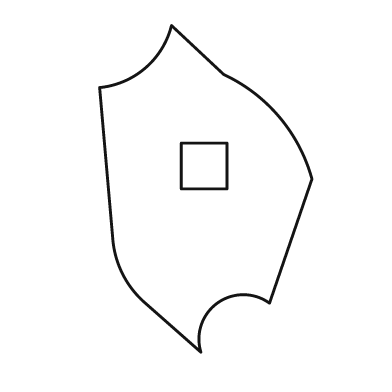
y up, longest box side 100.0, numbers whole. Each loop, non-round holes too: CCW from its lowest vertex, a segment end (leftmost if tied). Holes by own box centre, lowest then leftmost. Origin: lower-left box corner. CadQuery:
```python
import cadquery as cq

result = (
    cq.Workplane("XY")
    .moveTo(31.0, 0.0)
    .threePointArc((36.0, 15.0), (52.0, 15.0))
    .lineTo(65.0, 53.0)
    .threePointArc((55.0, 72.0), (38.0, 85.0))
    .lineTo(22.0, 100.0)
    .threePointArc((14.0, 87.0), (0.0, 81.0))
    .lineTo(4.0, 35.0)
    .threePointArc((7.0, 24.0), (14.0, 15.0))
    .close()
    .moveTo(25.0, 50.0)
    .lineTo(39.0, 50.0)
    .lineTo(39.0, 64.0)
    .lineTo(25.0, 64.0)
    .close()
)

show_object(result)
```